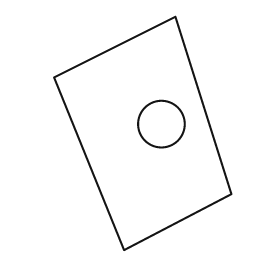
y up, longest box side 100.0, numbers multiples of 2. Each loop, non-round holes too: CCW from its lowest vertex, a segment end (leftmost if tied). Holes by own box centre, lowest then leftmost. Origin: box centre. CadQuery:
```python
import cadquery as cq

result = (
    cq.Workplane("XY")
    .moveTo(-8.0, -50.0)
    .lineTo(38.0, -26.0)
    .lineTo(14.0, 50.0)
    .lineTo(-38.0, 24.0)
    .close()
    .moveTo(8.0, 4.0)
    .circle(10.0)
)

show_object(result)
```